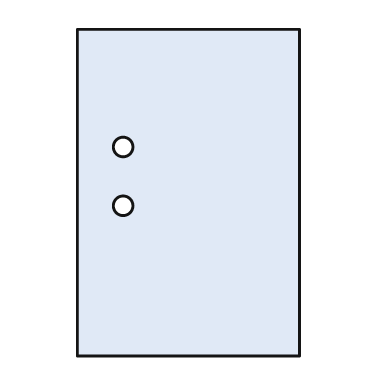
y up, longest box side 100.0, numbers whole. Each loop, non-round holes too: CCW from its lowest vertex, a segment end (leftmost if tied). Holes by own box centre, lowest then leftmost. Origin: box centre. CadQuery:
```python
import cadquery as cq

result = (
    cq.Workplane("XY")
    .moveTo(-34.0, -50.0)
    .lineTo(34.0, -50.0)
    .lineTo(34.0, 50.0)
    .lineTo(-34.0, 50.0)
    .close()
    .moveTo(-20.0, -4.0)
    .circle(3.0)
    .moveTo(-20.0, 14.0)
    .circle(3.0)
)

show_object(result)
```